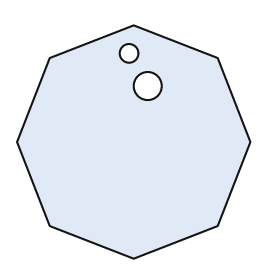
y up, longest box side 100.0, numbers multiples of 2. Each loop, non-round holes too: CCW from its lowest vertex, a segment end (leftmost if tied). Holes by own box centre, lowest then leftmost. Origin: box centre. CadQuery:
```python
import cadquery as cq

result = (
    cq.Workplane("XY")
    .moveTo(0.0, -50.0)
    .lineTo(36.0, -36.0)
    .lineTo(50.0, 0.0)
    .lineTo(36.0, 36.0)
    .lineTo(0.0, 50.0)
    .lineTo(-36.0, 36.0)
    .lineTo(-50.0, 0.0)
    .lineTo(-36.0, -36.0)
    .close()
    .moveTo(6.0, 24.0)
    .circle(6.0)
    .moveTo(-2.0, 38.0)
    .circle(4.0)
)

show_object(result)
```